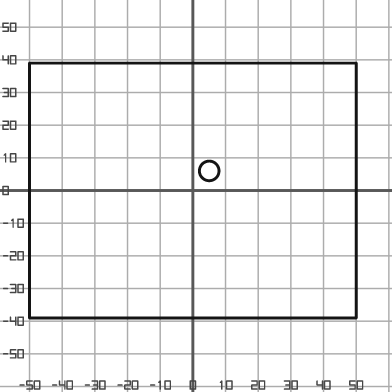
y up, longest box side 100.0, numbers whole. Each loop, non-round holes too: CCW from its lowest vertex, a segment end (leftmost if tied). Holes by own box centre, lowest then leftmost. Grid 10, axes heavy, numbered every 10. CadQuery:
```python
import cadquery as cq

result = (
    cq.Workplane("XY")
    .moveTo(-50.0, -39.0)
    .lineTo(50.0, -39.0)
    .lineTo(50.0, 39.0)
    .lineTo(-50.0, 39.0)
    .close()
    .moveTo(5.0, 6.0)
    .circle(3.0)
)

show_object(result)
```